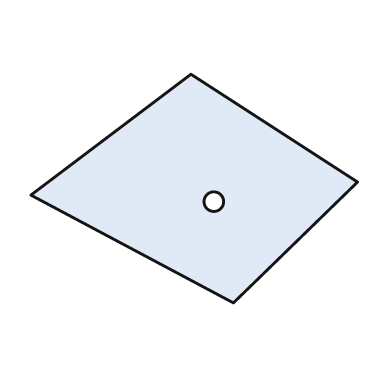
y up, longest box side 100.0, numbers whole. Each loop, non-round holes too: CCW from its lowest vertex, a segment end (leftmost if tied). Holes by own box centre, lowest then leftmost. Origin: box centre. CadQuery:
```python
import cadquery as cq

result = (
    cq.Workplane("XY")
    .moveTo(12.0, -35.0)
    .lineTo(50.0, 2.0)
    .lineTo(-1.0, 35.0)
    .lineTo(-50.0, -2.0)
    .close()
    .moveTo(6.0, -4.0)
    .circle(3.0)
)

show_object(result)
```